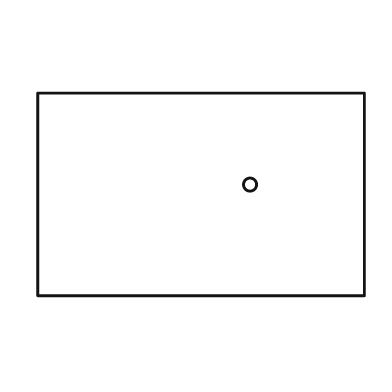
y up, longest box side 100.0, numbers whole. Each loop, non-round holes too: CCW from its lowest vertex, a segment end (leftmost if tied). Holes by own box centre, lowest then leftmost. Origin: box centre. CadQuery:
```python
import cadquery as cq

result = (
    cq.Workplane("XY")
    .moveTo(-50.0, -31.0)
    .lineTo(50.0, -31.0)
    .lineTo(50.0, 31.0)
    .lineTo(-50.0, 31.0)
    .close()
    .moveTo(15.0, 3.0)
    .circle(2.0)
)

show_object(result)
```